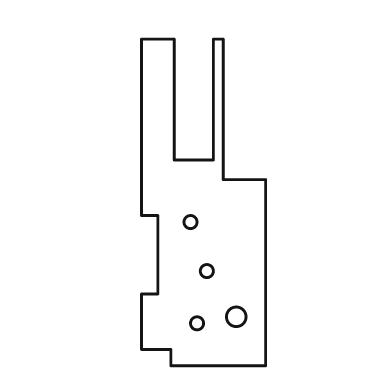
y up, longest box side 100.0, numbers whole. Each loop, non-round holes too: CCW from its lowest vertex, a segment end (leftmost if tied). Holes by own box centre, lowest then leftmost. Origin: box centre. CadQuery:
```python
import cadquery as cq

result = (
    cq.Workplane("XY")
    .moveTo(-10.0, -50.0)
    .lineTo(19.0, -50.0)
    .lineTo(19.0, 7.0)
    .lineTo(6.0, 7.0)
    .lineTo(6.0, 50.0)
    .lineTo(3.0, 50.0)
    .lineTo(3.0, 13.0)
    .lineTo(-9.0, 13.0)
    .lineTo(-9.0, 50.0)
    .lineTo(-19.0, 50.0)
    .lineTo(-19.0, -4.0)
    .lineTo(-14.0, -4.0)
    .lineTo(-14.0, -28.0)
    .lineTo(-19.0, -28.0)
    .lineTo(-19.0, -45.0)
    .lineTo(-10.0, -45.0)
    .close()
    .moveTo(-2.0, -37.0)
    .circle(2.0)
    .moveTo(10.0, -35.0)
    .circle(3.0)
    .moveTo(1.0, -21.0)
    .circle(2.0)
    .moveTo(-4.0, -6.0)
    .circle(2.0)
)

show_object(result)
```